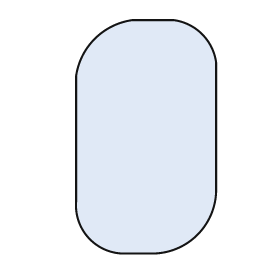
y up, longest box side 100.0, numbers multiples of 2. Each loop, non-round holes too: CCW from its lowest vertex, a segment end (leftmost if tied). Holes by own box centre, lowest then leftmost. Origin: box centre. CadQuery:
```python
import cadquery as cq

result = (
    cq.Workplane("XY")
    .moveTo(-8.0, -50.0)
    .lineTo(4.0, -50.0)
    .threePointArc((22.0, -42.0), (30.0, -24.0))
    .lineTo(30.0, 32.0)
    .threePointArc((24.0, 44.0), (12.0, 50.0))
    .lineTo(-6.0, 50.0)
    .threePointArc((-22.0, 42.0), (-30.0, 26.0))
    .lineTo(-30.0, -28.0)
    .threePointArc((-24.0, -44.0), (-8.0, -50.0))
    .close()
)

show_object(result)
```